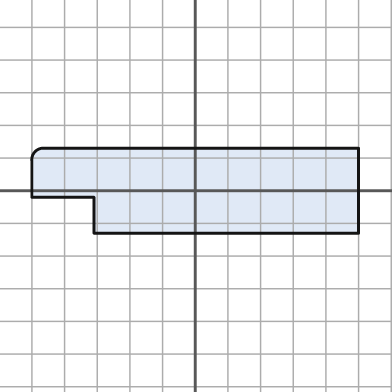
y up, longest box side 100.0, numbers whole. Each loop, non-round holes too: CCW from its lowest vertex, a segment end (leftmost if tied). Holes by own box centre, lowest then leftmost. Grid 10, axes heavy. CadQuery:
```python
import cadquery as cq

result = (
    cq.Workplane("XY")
    .moveTo(-31.0, -13.0)
    .lineTo(50.0, -13.0)
    .lineTo(50.0, 13.0)
    .lineTo(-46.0, 13.0)
    .threePointArc((-49.0, 12.0), (-50.0, 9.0))
    .lineTo(-50.0, -2.0)
    .lineTo(-31.0, -2.0)
    .close()
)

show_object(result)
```